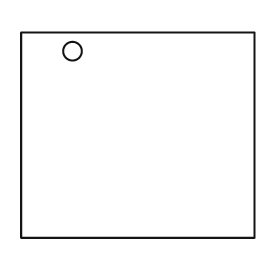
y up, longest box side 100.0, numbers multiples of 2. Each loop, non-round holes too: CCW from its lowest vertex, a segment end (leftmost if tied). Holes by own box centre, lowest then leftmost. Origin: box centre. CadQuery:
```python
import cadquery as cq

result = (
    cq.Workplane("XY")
    .moveTo(-50.0, -44.0)
    .lineTo(50.0, -44.0)
    .lineTo(50.0, 44.0)
    .lineTo(-50.0, 44.0)
    .close()
    .moveTo(-28.0, 36.0)
    .circle(4.0)
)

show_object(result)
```